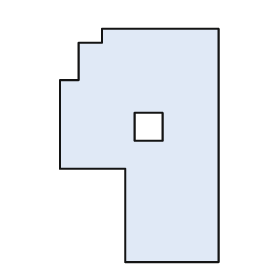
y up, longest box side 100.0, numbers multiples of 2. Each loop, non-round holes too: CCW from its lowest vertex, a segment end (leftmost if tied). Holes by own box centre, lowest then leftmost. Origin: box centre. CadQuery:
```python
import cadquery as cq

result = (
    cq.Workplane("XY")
    .moveTo(-6.0, -50.0)
    .lineTo(34.0, -50.0)
    .lineTo(34.0, 50.0)
    .lineTo(-16.0, 50.0)
    .lineTo(-16.0, 44.0)
    .lineTo(-26.0, 44.0)
    .lineTo(-26.0, 28.0)
    .lineTo(-34.0, 28.0)
    .lineTo(-34.0, -10.0)
    .lineTo(-6.0, -10.0)
    .close()
    .moveTo(-2.0, 2.0)
    .lineTo(10.0, 2.0)
    .lineTo(10.0, 14.0)
    .lineTo(-2.0, 14.0)
    .close()
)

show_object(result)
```